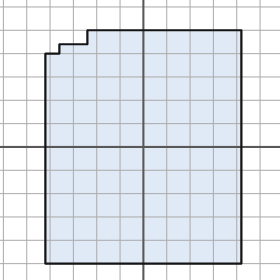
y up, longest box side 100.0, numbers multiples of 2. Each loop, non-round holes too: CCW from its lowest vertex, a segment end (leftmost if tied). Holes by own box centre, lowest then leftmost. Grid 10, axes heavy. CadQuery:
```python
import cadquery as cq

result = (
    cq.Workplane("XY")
    .moveTo(-42.0, -50.0)
    .lineTo(42.0, -50.0)
    .lineTo(42.0, 50.0)
    .lineTo(-24.0, 50.0)
    .lineTo(-24.0, 44.0)
    .lineTo(-36.0, 44.0)
    .lineTo(-36.0, 40.0)
    .lineTo(-42.0, 40.0)
    .close()
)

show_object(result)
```